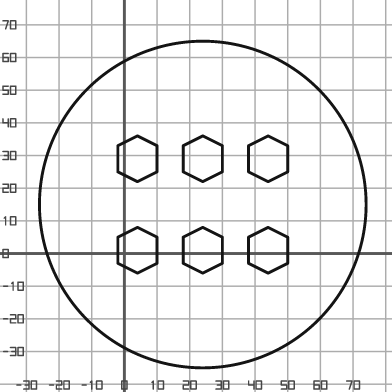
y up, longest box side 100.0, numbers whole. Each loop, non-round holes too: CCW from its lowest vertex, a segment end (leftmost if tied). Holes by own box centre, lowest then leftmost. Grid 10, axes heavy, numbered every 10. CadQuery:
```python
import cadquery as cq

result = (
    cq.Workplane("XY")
    .moveTo(24.0, 15.0)
    .circle(50.0)
    .moveTo(4.0, -6.0)
    .lineTo(10.0, -3.0)
    .lineTo(10.0, 5.0)
    .lineTo(4.0, 8.0)
    .lineTo(-2.0, 5.0)
    .lineTo(-2.0, -3.0)
    .close()
    .moveTo(24.0, -6.0)
    .lineTo(30.0, -3.0)
    .lineTo(30.0, 5.0)
    .lineTo(24.0, 8.0)
    .lineTo(18.0, 5.0)
    .lineTo(18.0, -3.0)
    .close()
    .moveTo(44.0, -6.0)
    .lineTo(50.0, -3.0)
    .lineTo(50.0, 5.0)
    .lineTo(44.0, 8.0)
    .lineTo(38.0, 5.0)
    .lineTo(38.0, -3.0)
    .close()
    .moveTo(4.0, 22.0)
    .lineTo(10.0, 25.0)
    .lineTo(10.0, 33.0)
    .lineTo(4.0, 36.0)
    .lineTo(-2.0, 33.0)
    .lineTo(-2.0, 25.0)
    .close()
    .moveTo(24.0, 22.0)
    .lineTo(30.0, 25.0)
    .lineTo(30.0, 33.0)
    .lineTo(24.0, 36.0)
    .lineTo(18.0, 33.0)
    .lineTo(18.0, 25.0)
    .close()
    .moveTo(44.0, 22.0)
    .lineTo(50.0, 25.0)
    .lineTo(50.0, 33.0)
    .lineTo(44.0, 36.0)
    .lineTo(38.0, 33.0)
    .lineTo(38.0, 25.0)
    .close()
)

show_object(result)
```